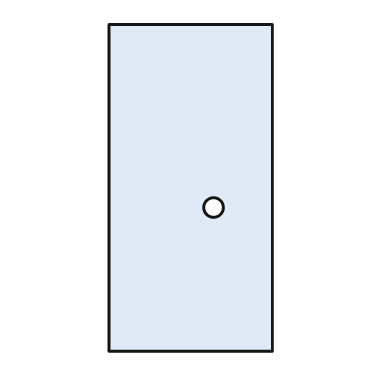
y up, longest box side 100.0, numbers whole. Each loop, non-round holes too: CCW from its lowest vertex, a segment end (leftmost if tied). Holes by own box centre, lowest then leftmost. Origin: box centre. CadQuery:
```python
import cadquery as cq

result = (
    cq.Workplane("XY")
    .moveTo(-25.0, -50.0)
    .lineTo(25.0, -50.0)
    .lineTo(25.0, 50.0)
    .lineTo(-25.0, 50.0)
    .close()
    .moveTo(7.0, -6.0)
    .circle(3.0)
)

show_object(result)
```